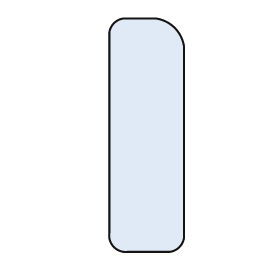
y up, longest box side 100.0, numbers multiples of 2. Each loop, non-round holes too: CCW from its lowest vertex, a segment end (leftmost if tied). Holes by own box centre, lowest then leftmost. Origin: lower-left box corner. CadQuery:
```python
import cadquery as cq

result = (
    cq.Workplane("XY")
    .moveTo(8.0, 0.0)
    .lineTo(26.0, 0.0)
    .threePointArc((30.0, 2.0), (32.0, 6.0))
    .lineTo(32.0, 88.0)
    .threePointArc((28.0, 96.0), (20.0, 100.0))
    .lineTo(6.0, 100.0)
    .threePointArc((2.0, 98.0), (0.0, 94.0))
    .lineTo(0.0, 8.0)
    .threePointArc((2.0, 2.0), (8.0, 0.0))
    .close()
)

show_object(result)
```